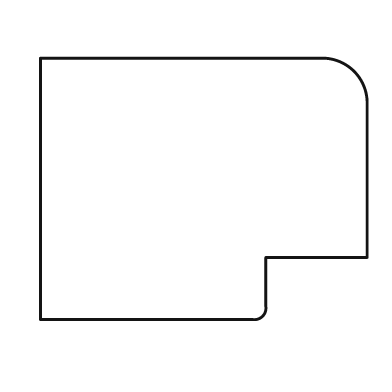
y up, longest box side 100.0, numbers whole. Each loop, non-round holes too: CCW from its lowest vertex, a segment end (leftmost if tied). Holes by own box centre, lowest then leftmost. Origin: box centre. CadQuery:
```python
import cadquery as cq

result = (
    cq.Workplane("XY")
    .moveTo(-50.0, -40.0)
    .lineTo(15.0, -40.0)
    .threePointArc((18.0, -39.0), (19.0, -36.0))
    .lineTo(19.0, -21.0)
    .lineTo(50.0, -21.0)
    .lineTo(50.0, 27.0)
    .threePointArc((46.0, 36.0), (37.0, 40.0))
    .lineTo(-50.0, 40.0)
    .close()
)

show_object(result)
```